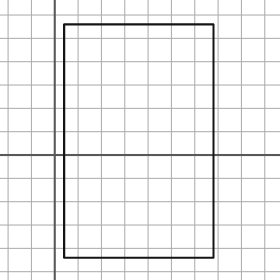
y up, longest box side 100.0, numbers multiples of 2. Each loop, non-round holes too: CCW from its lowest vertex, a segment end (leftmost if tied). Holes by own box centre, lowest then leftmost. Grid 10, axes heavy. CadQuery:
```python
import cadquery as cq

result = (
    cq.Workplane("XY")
    .moveTo(4.0, -44.0)
    .lineTo(68.0, -44.0)
    .lineTo(68.0, 56.0)
    .lineTo(4.0, 56.0)
    .close()
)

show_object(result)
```